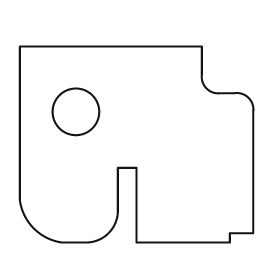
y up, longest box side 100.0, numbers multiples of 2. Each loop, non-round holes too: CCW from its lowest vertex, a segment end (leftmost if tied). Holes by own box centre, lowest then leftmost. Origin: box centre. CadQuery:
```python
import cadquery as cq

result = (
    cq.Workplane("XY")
    .moveTo(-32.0, -42.0)
    .lineTo(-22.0, -42.0)
    .threePointArc((-12.0, -38.0), (-8.0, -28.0))
    .lineTo(-8.0, -10.0)
    .lineTo(0.0, -10.0)
    .lineTo(0.0, -42.0)
    .lineTo(40.0, -42.0)
    .lineTo(40.0, -38.0)
    .lineTo(50.0, -38.0)
    .lineTo(50.0, 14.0)
    .threePointArc((48.0, 20.0), (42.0, 22.0))
    .lineTo(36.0, 22.0)
    .threePointArc((30.0, 24.0), (28.0, 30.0))
    .lineTo(28.0, 42.0)
    .lineTo(-50.0, 42.0)
    .lineTo(-50.0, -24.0)
    .threePointArc((-44.0, -36.0), (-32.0, -42.0))
    .close()
    .moveTo(-26.0, 14.0)
    .circle(10.0)
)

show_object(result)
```